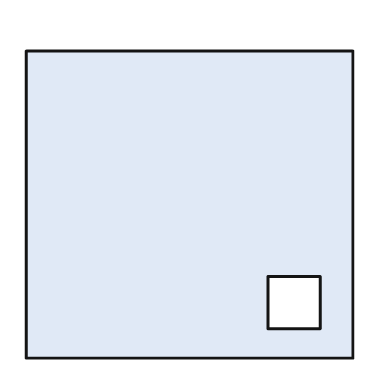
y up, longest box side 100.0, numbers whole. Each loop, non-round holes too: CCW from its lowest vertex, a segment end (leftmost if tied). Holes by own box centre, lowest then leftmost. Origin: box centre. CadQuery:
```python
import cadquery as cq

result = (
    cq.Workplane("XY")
    .moveTo(-50.0, -47.0)
    .lineTo(50.0, -47.0)
    .lineTo(50.0, 47.0)
    .lineTo(-50.0, 47.0)
    .close()
    .moveTo(24.0, -38.0)
    .lineTo(40.0, -38.0)
    .lineTo(40.0, -22.0)
    .lineTo(24.0, -22.0)
    .close()
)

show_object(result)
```